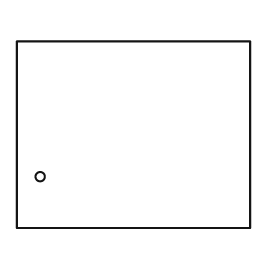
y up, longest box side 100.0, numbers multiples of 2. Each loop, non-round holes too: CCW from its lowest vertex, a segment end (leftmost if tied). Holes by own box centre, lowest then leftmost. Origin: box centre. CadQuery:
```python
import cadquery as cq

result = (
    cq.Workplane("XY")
    .moveTo(-50.0, -40.0)
    .lineTo(50.0, -40.0)
    .lineTo(50.0, 40.0)
    .lineTo(-50.0, 40.0)
    .close()
    .moveTo(-40.0, -18.0)
    .circle(2.0)
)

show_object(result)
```